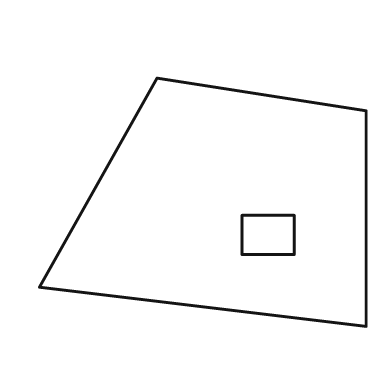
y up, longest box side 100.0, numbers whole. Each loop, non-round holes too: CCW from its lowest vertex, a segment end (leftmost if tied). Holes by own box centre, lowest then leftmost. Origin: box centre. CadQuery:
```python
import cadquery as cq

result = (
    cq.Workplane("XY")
    .moveTo(50.0, -38.0)
    .lineTo(50.0, 28.0)
    .lineTo(-14.0, 38.0)
    .lineTo(-50.0, -26.0)
    .close()
    .moveTo(12.0, -16.0)
    .lineTo(28.0, -16.0)
    .lineTo(28.0, -4.0)
    .lineTo(12.0, -4.0)
    .close()
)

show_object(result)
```